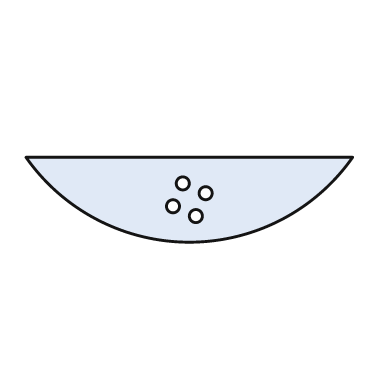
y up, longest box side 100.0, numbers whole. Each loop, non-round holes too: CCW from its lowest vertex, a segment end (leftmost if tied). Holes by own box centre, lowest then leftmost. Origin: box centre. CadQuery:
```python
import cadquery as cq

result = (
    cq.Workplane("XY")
    .moveTo(-50.0, 13.0)
    .threePointArc((0.0, -13.0), (50.0, 13.0))
    .close()
    .moveTo(2.0, -5.0)
    .circle(2.0)
    .moveTo(-5.0, -2.0)
    .circle(2.0)
    .moveTo(5.0, 2.0)
    .circle(2.0)
    .moveTo(-2.0, 5.0)
    .circle(2.0)
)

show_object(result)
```